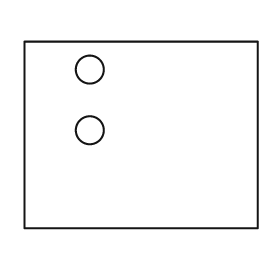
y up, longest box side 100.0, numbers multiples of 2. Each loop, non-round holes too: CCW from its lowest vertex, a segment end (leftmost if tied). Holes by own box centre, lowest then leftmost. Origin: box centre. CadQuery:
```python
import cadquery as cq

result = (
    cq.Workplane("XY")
    .moveTo(-50.0, -40.0)
    .lineTo(50.0, -40.0)
    .lineTo(50.0, 40.0)
    .lineTo(-50.0, 40.0)
    .close()
    .moveTo(-22.0, 2.0)
    .circle(6.0)
    .moveTo(-22.0, 28.0)
    .circle(6.0)
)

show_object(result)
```